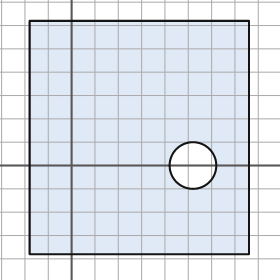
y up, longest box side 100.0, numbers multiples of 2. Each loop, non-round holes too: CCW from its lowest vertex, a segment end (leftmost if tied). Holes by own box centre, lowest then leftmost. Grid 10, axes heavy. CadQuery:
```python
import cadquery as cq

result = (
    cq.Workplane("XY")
    .moveTo(-18.0, -38.0)
    .lineTo(76.0, -38.0)
    .lineTo(76.0, 62.0)
    .lineTo(-18.0, 62.0)
    .close()
    .moveTo(52.0, 0.0)
    .circle(10.0)
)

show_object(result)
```